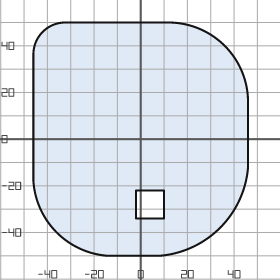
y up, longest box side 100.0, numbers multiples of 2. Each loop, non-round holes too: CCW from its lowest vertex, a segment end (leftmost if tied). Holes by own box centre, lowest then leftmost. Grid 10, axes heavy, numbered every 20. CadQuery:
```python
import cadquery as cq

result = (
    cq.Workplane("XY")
    .moveTo(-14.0, -50.0)
    .lineTo(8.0, -50.0)
    .threePointArc((34.0, -38.0), (46.0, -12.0))
    .lineTo(46.0, 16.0)
    .threePointArc((36.0, 40.0), (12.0, 50.0))
    .lineTo(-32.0, 50.0)
    .threePointArc((-42.0, 46.0), (-46.0, 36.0))
    .lineTo(-46.0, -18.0)
    .threePointArc((-36.0, -40.0), (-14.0, -50.0))
    .close()
    .moveTo(-2.0, -34.0)
    .lineTo(10.0, -34.0)
    .lineTo(10.0, -22.0)
    .lineTo(-2.0, -22.0)
    .close()
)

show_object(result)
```